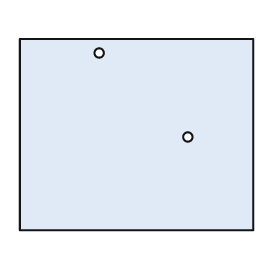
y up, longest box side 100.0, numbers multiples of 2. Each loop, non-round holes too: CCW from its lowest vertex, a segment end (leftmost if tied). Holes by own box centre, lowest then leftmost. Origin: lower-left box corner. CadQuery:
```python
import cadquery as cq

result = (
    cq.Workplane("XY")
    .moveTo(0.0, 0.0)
    .lineTo(100.0, 0.0)
    .lineTo(100.0, 82.0)
    .lineTo(0.0, 82.0)
    .close()
    .moveTo(72.0, 40.0)
    .circle(2.0)
    .moveTo(34.0, 76.0)
    .circle(2.0)
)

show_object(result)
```